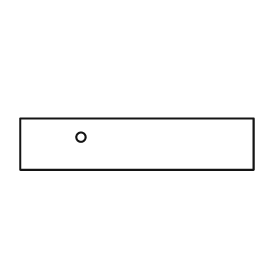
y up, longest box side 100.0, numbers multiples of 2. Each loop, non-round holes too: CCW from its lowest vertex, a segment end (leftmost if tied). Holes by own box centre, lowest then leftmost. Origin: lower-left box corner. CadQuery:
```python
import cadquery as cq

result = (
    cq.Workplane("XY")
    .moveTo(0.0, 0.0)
    .lineTo(100.0, 0.0)
    .lineTo(100.0, 22.0)
    .lineTo(0.0, 22.0)
    .close()
    .moveTo(26.0, 14.0)
    .circle(2.0)
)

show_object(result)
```